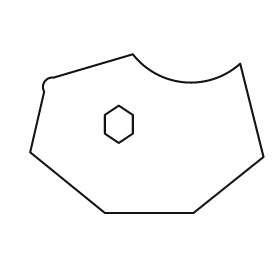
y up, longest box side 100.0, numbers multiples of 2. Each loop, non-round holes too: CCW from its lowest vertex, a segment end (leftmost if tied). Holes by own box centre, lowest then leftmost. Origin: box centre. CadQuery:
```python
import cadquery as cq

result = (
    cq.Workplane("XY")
    .moveTo(-18.0, -34.0)
    .lineTo(20.0, -34.0)
    .lineTo(50.0, -10.0)
    .lineTo(40.0, 30.0)
    .threePointArc((16.0, 22.0), (-6.0, 34.0))
    .lineTo(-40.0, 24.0)
    .threePointArc((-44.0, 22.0), (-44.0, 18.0))
    .lineTo(-50.0, -8.0)
    .close()
    .moveTo(-12.0, -4.0)
    .lineTo(-6.0, 0.0)
    .lineTo(-6.0, 8.0)
    .lineTo(-12.0, 12.0)
    .lineTo(-18.0, 8.0)
    .lineTo(-18.0, 0.0)
    .close()
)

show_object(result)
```